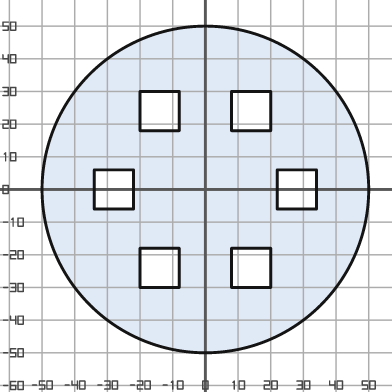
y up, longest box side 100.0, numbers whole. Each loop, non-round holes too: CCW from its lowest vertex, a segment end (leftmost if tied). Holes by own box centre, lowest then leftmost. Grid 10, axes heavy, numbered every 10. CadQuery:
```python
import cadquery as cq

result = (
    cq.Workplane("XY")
    .moveTo(0.0, 0.0)
    .circle(50.0)
    .moveTo(-20.0, -30.0)
    .lineTo(-8.0, -30.0)
    .lineTo(-8.0, -18.0)
    .lineTo(-20.0, -18.0)
    .close()
    .moveTo(8.0, -30.0)
    .lineTo(20.0, -30.0)
    .lineTo(20.0, -18.0)
    .lineTo(8.0, -18.0)
    .close()
    .moveTo(-34.0, -6.0)
    .lineTo(-22.0, -6.0)
    .lineTo(-22.0, 6.0)
    .lineTo(-34.0, 6.0)
    .close()
    .moveTo(22.0, -6.0)
    .lineTo(34.0, -6.0)
    .lineTo(34.0, 6.0)
    .lineTo(22.0, 6.0)
    .close()
    .moveTo(-20.0, 18.0)
    .lineTo(-8.0, 18.0)
    .lineTo(-8.0, 30.0)
    .lineTo(-20.0, 30.0)
    .close()
    .moveTo(8.0, 18.0)
    .lineTo(20.0, 18.0)
    .lineTo(20.0, 30.0)
    .lineTo(8.0, 30.0)
    .close()
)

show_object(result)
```